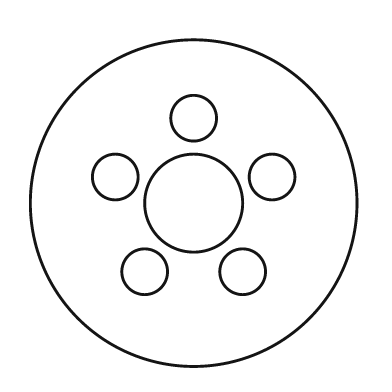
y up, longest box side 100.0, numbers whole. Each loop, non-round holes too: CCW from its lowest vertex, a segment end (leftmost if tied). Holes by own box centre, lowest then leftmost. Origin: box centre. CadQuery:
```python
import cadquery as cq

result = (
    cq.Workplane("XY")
    .moveTo(0.0, 0.0)
    .circle(50.0)
    .moveTo(-15.0, -21.0)
    .circle(7.0)
    .moveTo(15.0, -21.0)
    .circle(7.0)
    .moveTo(0.0, 0.0)
    .circle(15.0)
    .moveTo(-24.0, 8.0)
    .circle(7.0)
    .moveTo(24.0, 8.0)
    .circle(7.0)
    .moveTo(0.0, 26.0)
    .circle(7.0)
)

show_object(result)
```